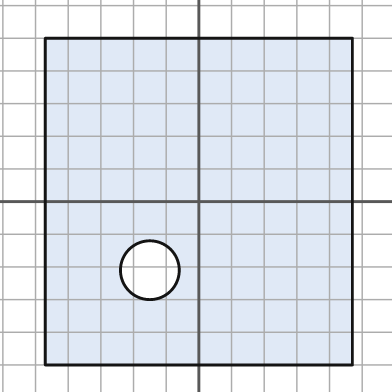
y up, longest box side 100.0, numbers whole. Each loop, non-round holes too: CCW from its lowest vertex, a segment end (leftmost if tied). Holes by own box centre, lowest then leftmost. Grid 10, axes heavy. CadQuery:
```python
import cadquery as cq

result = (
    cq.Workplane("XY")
    .moveTo(-47.0, -50.0)
    .lineTo(47.0, -50.0)
    .lineTo(47.0, 50.0)
    .lineTo(-47.0, 50.0)
    .close()
    .moveTo(-15.0, -21.0)
    .circle(9.0)
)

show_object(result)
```